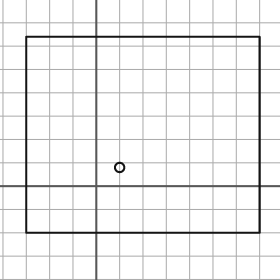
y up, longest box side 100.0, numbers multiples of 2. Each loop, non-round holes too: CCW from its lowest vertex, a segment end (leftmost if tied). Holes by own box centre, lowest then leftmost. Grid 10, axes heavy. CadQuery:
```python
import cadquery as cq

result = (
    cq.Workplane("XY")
    .moveTo(-30.0, -20.0)
    .lineTo(70.0, -20.0)
    .lineTo(70.0, 64.0)
    .lineTo(-30.0, 64.0)
    .close()
    .moveTo(10.0, 8.0)
    .circle(2.0)
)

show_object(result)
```